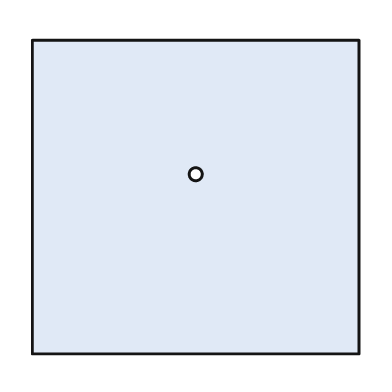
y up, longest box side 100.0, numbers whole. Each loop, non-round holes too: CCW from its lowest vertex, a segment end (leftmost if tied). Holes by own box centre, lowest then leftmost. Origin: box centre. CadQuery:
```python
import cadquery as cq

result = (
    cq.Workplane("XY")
    .moveTo(-50.0, -48.0)
    .lineTo(50.0, -48.0)
    .lineTo(50.0, 48.0)
    .lineTo(-50.0, 48.0)
    .close()
    .moveTo(0.0, 7.0)
    .circle(2.0)
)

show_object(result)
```